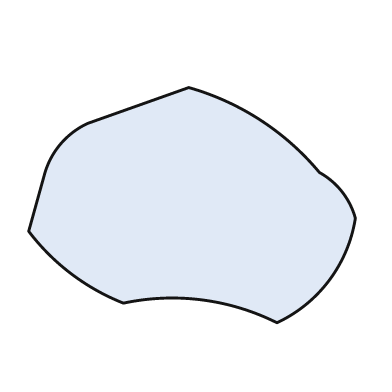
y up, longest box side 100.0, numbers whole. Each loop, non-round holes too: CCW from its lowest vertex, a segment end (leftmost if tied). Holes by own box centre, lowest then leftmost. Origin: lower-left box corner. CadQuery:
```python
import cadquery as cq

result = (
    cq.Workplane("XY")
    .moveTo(76.0, 0.0)
    .threePointArc((92.0, 13.0), (100.0, 32.0))
    .threePointArc((96.0, 40.0), (89.0, 46.0))
    .threePointArc((71.0, 62.0), (49.0, 72.0))
    .lineTo(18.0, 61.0)
    .threePointArc((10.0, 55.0), (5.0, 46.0))
    .lineTo(0.0, 28.0)
    .threePointArc((13.0, 15.0), (29.0, 6.0))
    .threePointArc((53.0, 7.0), (76.0, 0.0))
    .close()
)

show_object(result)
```